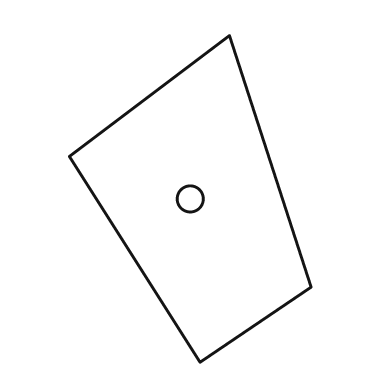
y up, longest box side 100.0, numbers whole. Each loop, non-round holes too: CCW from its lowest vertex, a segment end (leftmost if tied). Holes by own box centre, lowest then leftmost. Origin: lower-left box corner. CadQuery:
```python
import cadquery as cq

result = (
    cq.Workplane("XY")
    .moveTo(40.0, 0.0)
    .lineTo(74.0, 23.0)
    .lineTo(49.0, 100.0)
    .lineTo(0.0, 63.0)
    .close()
    .moveTo(37.0, 50.0)
    .circle(4.0)
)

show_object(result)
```